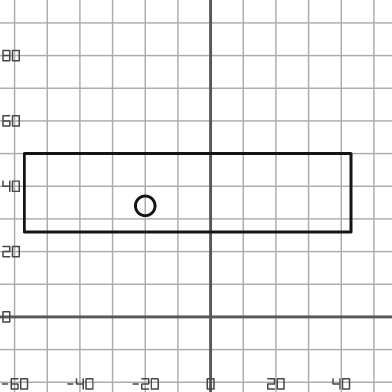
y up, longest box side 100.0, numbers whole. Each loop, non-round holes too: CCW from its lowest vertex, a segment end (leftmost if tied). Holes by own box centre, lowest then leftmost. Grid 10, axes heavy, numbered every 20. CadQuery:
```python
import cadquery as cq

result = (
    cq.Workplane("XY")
    .moveTo(-57.0, 26.0)
    .lineTo(43.0, 26.0)
    .lineTo(43.0, 50.0)
    .lineTo(-57.0, 50.0)
    .close()
    .moveTo(-20.0, 34.0)
    .circle(3.0)
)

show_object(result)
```